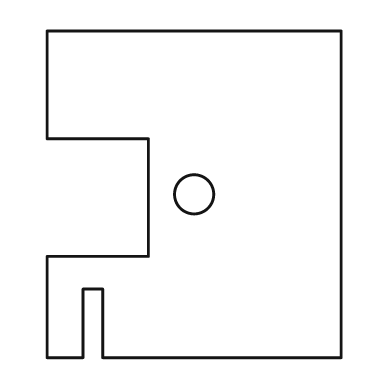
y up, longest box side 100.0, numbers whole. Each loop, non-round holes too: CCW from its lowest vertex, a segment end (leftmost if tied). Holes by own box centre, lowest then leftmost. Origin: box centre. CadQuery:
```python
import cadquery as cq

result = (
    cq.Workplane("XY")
    .moveTo(-45.0, -50.0)
    .lineTo(-34.0, -50.0)
    .lineTo(-34.0, -29.0)
    .lineTo(-28.0, -29.0)
    .lineTo(-28.0, -50.0)
    .lineTo(45.0, -50.0)
    .lineTo(45.0, 50.0)
    .lineTo(-45.0, 50.0)
    .lineTo(-45.0, 17.0)
    .lineTo(-14.0, 17.0)
    .lineTo(-14.0, -19.0)
    .lineTo(-45.0, -19.0)
    .close()
    .moveTo(0.0, 0.0)
    .circle(6.0)
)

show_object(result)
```